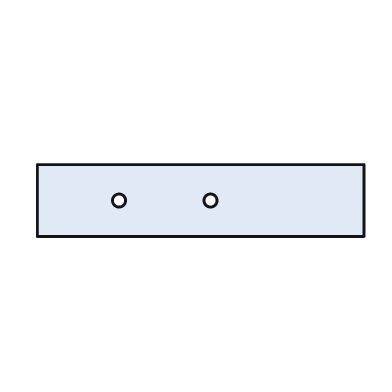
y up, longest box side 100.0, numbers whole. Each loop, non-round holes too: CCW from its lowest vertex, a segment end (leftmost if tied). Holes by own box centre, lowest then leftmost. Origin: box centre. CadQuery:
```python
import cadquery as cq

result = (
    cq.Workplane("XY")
    .moveTo(-50.0, -11.0)
    .lineTo(50.0, -11.0)
    .lineTo(50.0, 11.0)
    .lineTo(-50.0, 11.0)
    .close()
    .moveTo(-25.0, 0.0)
    .circle(2.0)
    .moveTo(3.0, 0.0)
    .circle(2.0)
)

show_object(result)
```